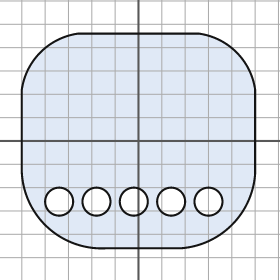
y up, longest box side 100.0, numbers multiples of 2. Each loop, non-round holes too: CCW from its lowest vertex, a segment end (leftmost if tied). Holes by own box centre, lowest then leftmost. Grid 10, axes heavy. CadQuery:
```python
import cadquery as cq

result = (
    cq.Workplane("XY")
    .moveTo(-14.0, -46.0)
    .lineTo(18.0, -46.0)
    .threePointArc((40.0, -36.0), (50.0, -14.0))
    .lineTo(50.0, 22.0)
    .threePointArc((42.0, 38.0), (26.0, 46.0))
    .lineTo(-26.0, 46.0)
    .threePointArc((-42.0, 38.0), (-50.0, 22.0))
    .lineTo(-50.0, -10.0)
    .threePointArc((-40.0, -36.0), (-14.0, -46.0))
    .close()
    .moveTo(-34.0, -26.0)
    .circle(6.0)
    .moveTo(-18.0, -26.0)
    .circle(6.0)
    .moveTo(-2.0, -26.0)
    .circle(6.0)
    .moveTo(14.0, -26.0)
    .circle(6.0)
    .moveTo(30.0, -26.0)
    .circle(6.0)
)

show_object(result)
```